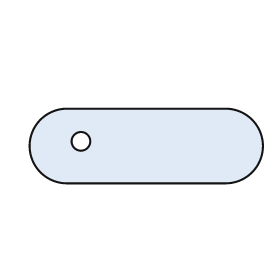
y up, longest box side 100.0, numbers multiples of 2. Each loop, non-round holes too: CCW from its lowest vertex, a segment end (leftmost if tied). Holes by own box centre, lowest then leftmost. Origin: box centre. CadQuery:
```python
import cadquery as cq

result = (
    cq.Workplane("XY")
    .moveTo(-34.0, -16.0)
    .lineTo(34.0, -16.0)
    .threePointArc((50.0, 0.0), (34.0, 16.0))
    .lineTo(-34.0, 16.0)
    .threePointArc((-50.0, 0.0), (-34.0, -16.0))
    .close()
    .moveTo(-28.0, 2.0)
    .circle(4.0)
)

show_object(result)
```